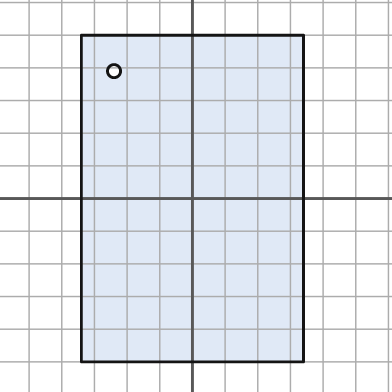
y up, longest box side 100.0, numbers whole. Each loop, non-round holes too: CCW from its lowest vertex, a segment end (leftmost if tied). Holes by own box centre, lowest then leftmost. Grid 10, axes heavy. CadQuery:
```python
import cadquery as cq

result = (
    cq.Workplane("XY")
    .moveTo(-34.0, -50.0)
    .lineTo(34.0, -50.0)
    .lineTo(34.0, 50.0)
    .lineTo(-34.0, 50.0)
    .close()
    .moveTo(-24.0, 39.0)
    .circle(2.0)
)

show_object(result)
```